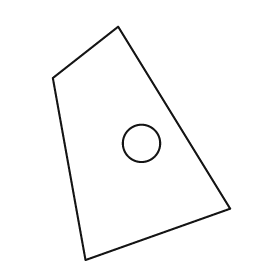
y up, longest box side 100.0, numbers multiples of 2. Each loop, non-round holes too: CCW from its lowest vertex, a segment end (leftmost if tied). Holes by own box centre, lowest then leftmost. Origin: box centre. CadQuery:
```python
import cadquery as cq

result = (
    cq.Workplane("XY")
    .moveTo(-24.0, -50.0)
    .lineTo(38.0, -28.0)
    .lineTo(-10.0, 50.0)
    .lineTo(-38.0, 28.0)
    .close()
    .moveTo(0.0, 0.0)
    .circle(8.0)
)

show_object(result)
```